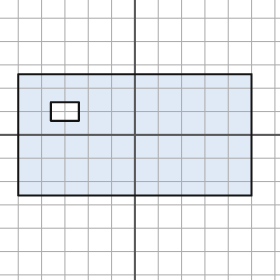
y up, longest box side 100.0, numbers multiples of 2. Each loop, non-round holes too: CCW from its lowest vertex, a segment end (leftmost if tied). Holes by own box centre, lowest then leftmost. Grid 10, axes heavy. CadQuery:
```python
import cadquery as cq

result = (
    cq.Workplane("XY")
    .moveTo(-50.0, -26.0)
    .lineTo(50.0, -26.0)
    .lineTo(50.0, 26.0)
    .lineTo(-50.0, 26.0)
    .close()
    .moveTo(-36.0, 6.0)
    .lineTo(-24.0, 6.0)
    .lineTo(-24.0, 14.0)
    .lineTo(-36.0, 14.0)
    .close()
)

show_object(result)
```